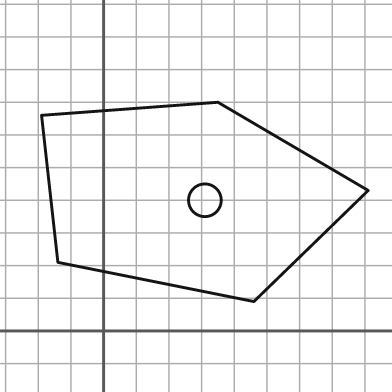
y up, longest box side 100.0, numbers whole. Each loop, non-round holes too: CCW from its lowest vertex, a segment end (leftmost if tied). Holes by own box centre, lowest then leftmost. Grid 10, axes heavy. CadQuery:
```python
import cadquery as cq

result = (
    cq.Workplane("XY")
    .moveTo(46.0, 9.0)
    .lineTo(81.0, 43.0)
    .lineTo(35.0, 70.0)
    .lineTo(-19.0, 66.0)
    .lineTo(-14.0, 21.0)
    .close()
    .moveTo(31.0, 40.0)
    .circle(5.0)
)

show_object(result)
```